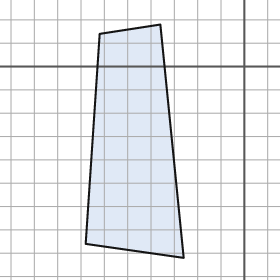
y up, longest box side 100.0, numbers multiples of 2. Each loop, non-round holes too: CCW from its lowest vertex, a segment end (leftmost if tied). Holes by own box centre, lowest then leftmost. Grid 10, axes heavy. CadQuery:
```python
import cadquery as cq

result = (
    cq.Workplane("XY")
    .moveTo(-26.0, -82.0)
    .lineTo(-36.0, 18.0)
    .lineTo(-62.0, 14.0)
    .lineTo(-68.0, -76.0)
    .close()
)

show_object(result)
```